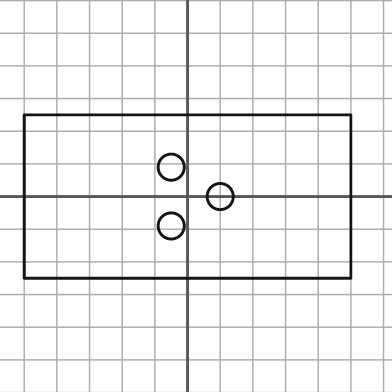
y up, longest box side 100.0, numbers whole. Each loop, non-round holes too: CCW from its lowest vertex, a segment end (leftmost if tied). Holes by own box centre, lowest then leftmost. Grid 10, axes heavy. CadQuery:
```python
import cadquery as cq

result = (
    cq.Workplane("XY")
    .moveTo(-50.0, -25.0)
    .lineTo(50.0, -25.0)
    .lineTo(50.0, 25.0)
    .lineTo(-50.0, 25.0)
    .close()
    .moveTo(-5.0, -9.0)
    .circle(4.0)
    .moveTo(10.0, 0.0)
    .circle(4.0)
    .moveTo(-5.0, 9.0)
    .circle(4.0)
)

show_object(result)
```